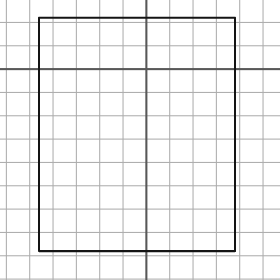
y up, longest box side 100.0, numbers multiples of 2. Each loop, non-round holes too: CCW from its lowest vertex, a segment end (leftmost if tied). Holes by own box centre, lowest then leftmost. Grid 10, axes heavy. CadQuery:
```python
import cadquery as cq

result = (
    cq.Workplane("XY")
    .moveTo(-46.0, -78.0)
    .lineTo(38.0, -78.0)
    .lineTo(38.0, 22.0)
    .lineTo(-46.0, 22.0)
    .close()
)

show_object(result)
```